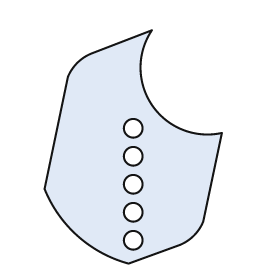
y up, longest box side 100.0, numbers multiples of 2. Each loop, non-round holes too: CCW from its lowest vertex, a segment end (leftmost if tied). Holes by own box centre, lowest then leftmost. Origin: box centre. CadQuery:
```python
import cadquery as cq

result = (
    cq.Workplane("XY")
    .moveTo(-2.0, -50.0)
    .lineTo(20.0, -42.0)
    .threePointArc((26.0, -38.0), (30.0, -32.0))
    .lineTo(38.0, 6.0)
    .threePointArc((8.0, 18.0), (8.0, 50.0))
    .lineTo(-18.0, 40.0)
    .threePointArc((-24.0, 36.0), (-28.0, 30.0))
    .lineTo(-38.0, -18.0)
    .threePointArc((-24.0, -38.0), (-2.0, -50.0))
    .close()
    .moveTo(0.0, -40.0)
    .circle(4.0)
    .moveTo(0.0, -28.0)
    .circle(4.0)
    .moveTo(0.0, -16.0)
    .circle(4.0)
    .moveTo(0.0, -4.0)
    .circle(4.0)
    .moveTo(0.0, 8.0)
    .circle(4.0)
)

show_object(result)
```